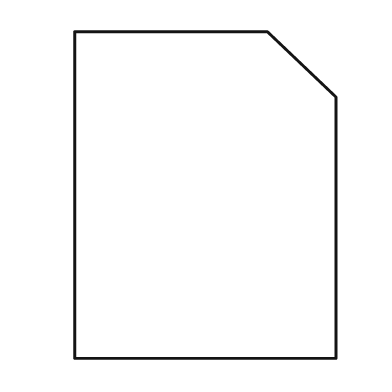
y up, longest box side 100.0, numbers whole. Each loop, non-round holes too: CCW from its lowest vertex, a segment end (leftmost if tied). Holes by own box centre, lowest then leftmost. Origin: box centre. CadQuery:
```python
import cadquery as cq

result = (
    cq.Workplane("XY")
    .moveTo(-40.0, -50.0)
    .lineTo(40.0, -50.0)
    .lineTo(40.0, 30.0)
    .lineTo(19.0, 50.0)
    .lineTo(-40.0, 50.0)
    .close()
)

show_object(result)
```